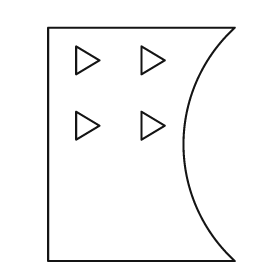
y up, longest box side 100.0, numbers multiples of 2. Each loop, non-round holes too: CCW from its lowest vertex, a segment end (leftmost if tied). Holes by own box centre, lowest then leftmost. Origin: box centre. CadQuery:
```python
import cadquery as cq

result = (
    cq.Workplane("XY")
    .moveTo(-40.0, -50.0)
    .lineTo(40.0, -50.0)
    .threePointArc((18.0, 0.0), (40.0, 50.0))
    .lineTo(-40.0, 50.0)
    .close()
    .moveTo(-28.0, 2.0)
    .lineTo(-18.0, 8.0)
    .lineTo(-28.0, 14.0)
    .close()
    .moveTo(0.0, 2.0)
    .lineTo(10.0, 8.0)
    .lineTo(0.0, 14.0)
    .close()
    .moveTo(-28.0, 30.0)
    .lineTo(-18.0, 36.0)
    .lineTo(-28.0, 42.0)
    .close()
    .moveTo(0.0, 30.0)
    .lineTo(10.0, 36.0)
    .lineTo(0.0, 42.0)
    .close()
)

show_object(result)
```